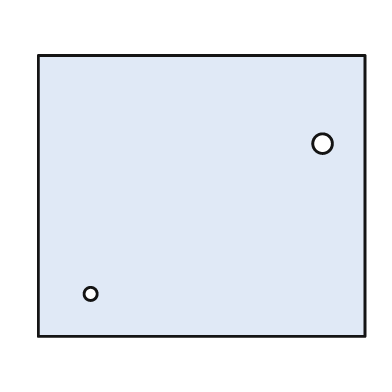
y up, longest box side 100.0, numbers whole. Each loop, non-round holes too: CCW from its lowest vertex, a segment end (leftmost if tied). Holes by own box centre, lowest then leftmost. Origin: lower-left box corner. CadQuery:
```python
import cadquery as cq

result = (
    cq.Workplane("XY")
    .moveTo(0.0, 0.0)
    .lineTo(100.0, 0.0)
    .lineTo(100.0, 86.0)
    .lineTo(0.0, 86.0)
    .close()
    .moveTo(16.0, 13.0)
    .circle(2.0)
    .moveTo(87.0, 59.0)
    .circle(3.0)
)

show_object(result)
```